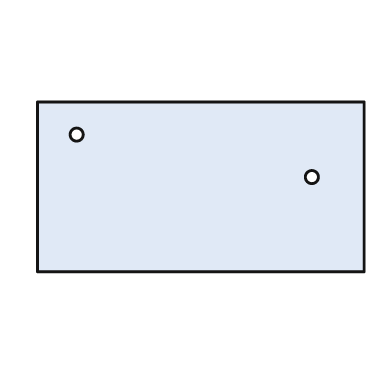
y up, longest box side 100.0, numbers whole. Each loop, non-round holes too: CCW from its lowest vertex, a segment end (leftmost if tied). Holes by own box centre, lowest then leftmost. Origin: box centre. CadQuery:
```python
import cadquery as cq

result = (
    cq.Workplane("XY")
    .moveTo(-50.0, -26.0)
    .lineTo(50.0, -26.0)
    .lineTo(50.0, 26.0)
    .lineTo(-50.0, 26.0)
    .close()
    .moveTo(34.0, 3.0)
    .circle(2.0)
    .moveTo(-38.0, 16.0)
    .circle(2.0)
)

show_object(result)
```